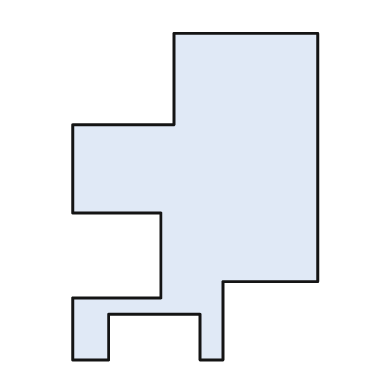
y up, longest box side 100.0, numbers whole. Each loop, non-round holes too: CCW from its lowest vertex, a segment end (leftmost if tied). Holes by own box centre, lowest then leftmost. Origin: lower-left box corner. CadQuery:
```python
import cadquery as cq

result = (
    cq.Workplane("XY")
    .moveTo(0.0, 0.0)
    .lineTo(11.0, 0.0)
    .lineTo(11.0, 14.0)
    .lineTo(39.0, 14.0)
    .lineTo(39.0, 0.0)
    .lineTo(46.0, 0.0)
    .lineTo(46.0, 24.0)
    .lineTo(75.0, 24.0)
    .lineTo(75.0, 100.0)
    .lineTo(31.0, 100.0)
    .lineTo(31.0, 72.0)
    .lineTo(0.0, 72.0)
    .lineTo(0.0, 45.0)
    .lineTo(27.0, 45.0)
    .lineTo(27.0, 19.0)
    .lineTo(0.0, 19.0)
    .close()
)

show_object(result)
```